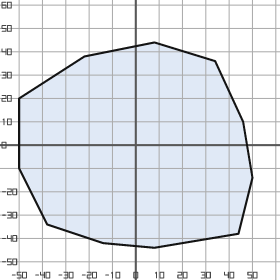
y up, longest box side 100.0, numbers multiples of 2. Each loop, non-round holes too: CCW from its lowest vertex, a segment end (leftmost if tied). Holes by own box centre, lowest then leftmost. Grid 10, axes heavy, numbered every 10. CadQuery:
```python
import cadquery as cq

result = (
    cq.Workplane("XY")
    .moveTo(8.0, -44.0)
    .lineTo(44.0, -38.0)
    .lineTo(50.0, -14.0)
    .lineTo(46.0, 10.0)
    .lineTo(34.0, 36.0)
    .lineTo(8.0, 44.0)
    .lineTo(-22.0, 38.0)
    .lineTo(-50.0, 20.0)
    .lineTo(-50.0, -10.0)
    .lineTo(-38.0, -34.0)
    .lineTo(-14.0, -42.0)
    .close()
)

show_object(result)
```